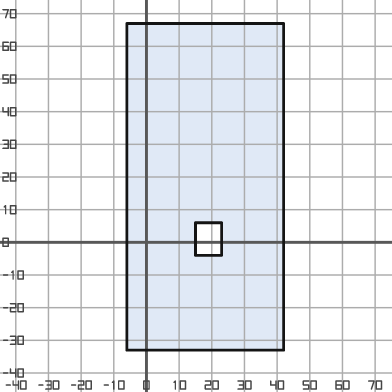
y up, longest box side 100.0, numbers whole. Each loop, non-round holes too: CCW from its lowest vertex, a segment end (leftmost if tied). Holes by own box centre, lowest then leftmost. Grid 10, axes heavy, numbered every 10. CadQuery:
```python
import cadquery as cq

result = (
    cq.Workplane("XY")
    .moveTo(-6.0, -33.0)
    .lineTo(42.0, -33.0)
    .lineTo(42.0, 67.0)
    .lineTo(-6.0, 67.0)
    .close()
    .moveTo(15.0, -4.0)
    .lineTo(23.0, -4.0)
    .lineTo(23.0, 6.0)
    .lineTo(15.0, 6.0)
    .close()
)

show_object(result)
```